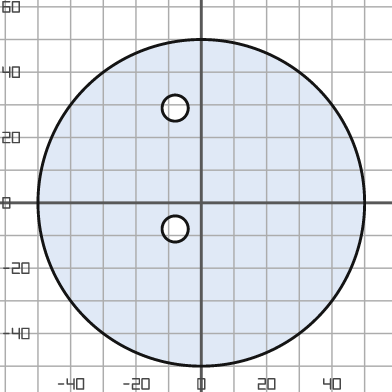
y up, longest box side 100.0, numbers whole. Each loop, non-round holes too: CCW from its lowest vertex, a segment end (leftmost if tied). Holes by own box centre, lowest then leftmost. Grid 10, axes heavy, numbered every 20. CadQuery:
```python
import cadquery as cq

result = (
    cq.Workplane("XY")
    .moveTo(0.0, 0.0)
    .circle(50.0)
    .moveTo(-8.0, -8.0)
    .circle(4.0)
    .moveTo(-8.0, 29.0)
    .circle(4.0)
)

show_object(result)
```